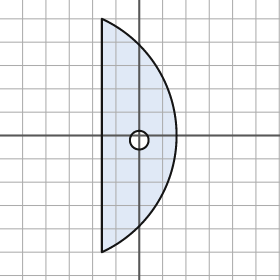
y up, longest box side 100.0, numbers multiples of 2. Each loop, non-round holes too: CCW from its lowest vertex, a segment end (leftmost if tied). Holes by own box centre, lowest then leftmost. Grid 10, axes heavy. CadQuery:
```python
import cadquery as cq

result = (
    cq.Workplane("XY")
    .moveTo(-16.0, -50.0)
    .threePointArc((16.0, 0.0), (-16.0, 50.0))
    .close()
    .moveTo(0.0, -2.0)
    .circle(4.0)
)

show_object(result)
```